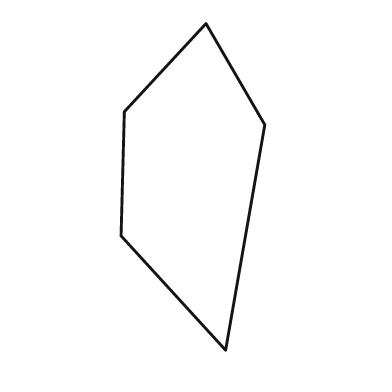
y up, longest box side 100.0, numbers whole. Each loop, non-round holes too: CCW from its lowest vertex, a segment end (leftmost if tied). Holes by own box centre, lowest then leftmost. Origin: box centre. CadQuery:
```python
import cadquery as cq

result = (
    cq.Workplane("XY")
    .moveTo(10.0, -50.0)
    .lineTo(22.0, 19.0)
    .lineTo(4.0, 50.0)
    .lineTo(-21.0, 23.0)
    .lineTo(-22.0, -15.0)
    .close()
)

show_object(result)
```